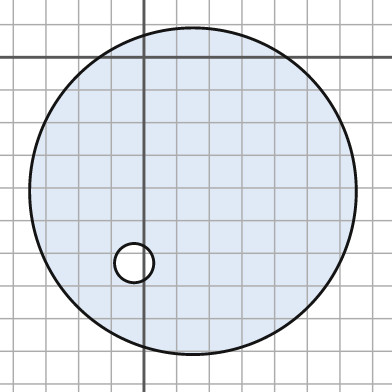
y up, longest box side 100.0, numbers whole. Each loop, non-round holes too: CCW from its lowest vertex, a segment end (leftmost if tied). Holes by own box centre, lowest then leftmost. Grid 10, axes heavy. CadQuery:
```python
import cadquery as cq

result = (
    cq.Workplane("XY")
    .moveTo(15.0, -41.0)
    .circle(50.0)
    .moveTo(-3.0, -63.0)
    .circle(6.0)
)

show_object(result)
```